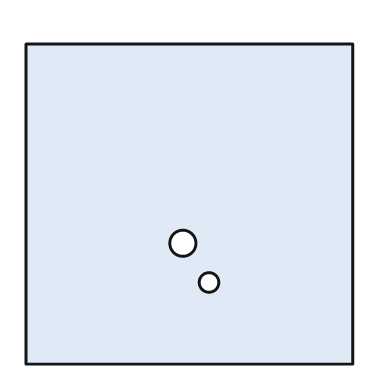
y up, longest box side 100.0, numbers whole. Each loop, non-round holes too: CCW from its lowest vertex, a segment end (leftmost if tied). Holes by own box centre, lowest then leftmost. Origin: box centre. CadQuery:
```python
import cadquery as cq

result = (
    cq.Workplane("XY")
    .moveTo(-50.0, -49.0)
    .lineTo(50.0, -49.0)
    .lineTo(50.0, 49.0)
    .lineTo(-50.0, 49.0)
    .close()
    .moveTo(6.0, -24.0)
    .circle(3.0)
    .moveTo(-2.0, -12.0)
    .circle(4.0)
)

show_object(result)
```